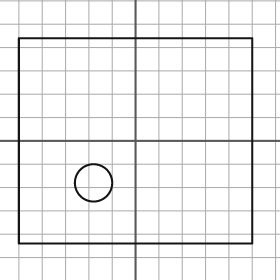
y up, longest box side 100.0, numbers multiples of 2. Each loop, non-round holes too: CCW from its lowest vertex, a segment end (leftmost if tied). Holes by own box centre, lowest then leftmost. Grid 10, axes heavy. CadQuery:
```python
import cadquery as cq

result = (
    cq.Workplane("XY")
    .moveTo(-50.0, -44.0)
    .lineTo(50.0, -44.0)
    .lineTo(50.0, 44.0)
    .lineTo(-50.0, 44.0)
    .close()
    .moveTo(-18.0, -18.0)
    .circle(8.0)
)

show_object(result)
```